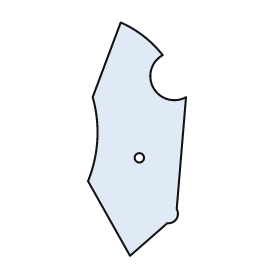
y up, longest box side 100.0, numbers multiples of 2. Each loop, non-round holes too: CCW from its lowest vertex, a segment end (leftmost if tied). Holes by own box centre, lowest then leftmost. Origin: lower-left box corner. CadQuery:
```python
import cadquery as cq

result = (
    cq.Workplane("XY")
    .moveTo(18.0, 0.0)
    .lineTo(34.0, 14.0)
    .threePointArc((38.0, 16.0), (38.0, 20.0))
    .lineTo(42.0, 68.0)
    .threePointArc((28.0, 72.0), (32.0, 86.0))
    .threePointArc((24.0, 94.0), (14.0, 100.0))
    .lineTo(2.0, 68.0)
    .threePointArc((4.0, 50.0), (0.0, 32.0))
    .close()
    .moveTo(22.0, 42.0)
    .circle(2.0)
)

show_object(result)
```